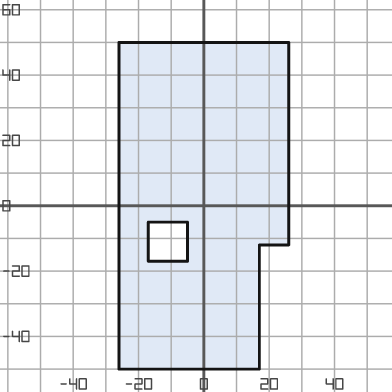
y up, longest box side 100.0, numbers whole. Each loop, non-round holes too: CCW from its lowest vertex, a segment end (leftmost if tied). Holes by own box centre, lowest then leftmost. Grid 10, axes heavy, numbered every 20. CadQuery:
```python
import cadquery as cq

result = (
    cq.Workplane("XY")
    .moveTo(-26.0, -50.0)
    .lineTo(17.0, -50.0)
    .lineTo(17.0, -12.0)
    .lineTo(26.0, -12.0)
    .lineTo(26.0, 50.0)
    .lineTo(-26.0, 50.0)
    .close()
    .moveTo(-17.0, -17.0)
    .lineTo(-5.0, -17.0)
    .lineTo(-5.0, -5.0)
    .lineTo(-17.0, -5.0)
    .close()
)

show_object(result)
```